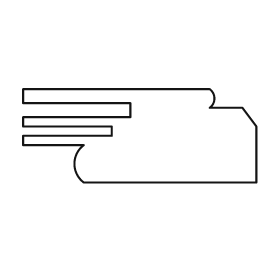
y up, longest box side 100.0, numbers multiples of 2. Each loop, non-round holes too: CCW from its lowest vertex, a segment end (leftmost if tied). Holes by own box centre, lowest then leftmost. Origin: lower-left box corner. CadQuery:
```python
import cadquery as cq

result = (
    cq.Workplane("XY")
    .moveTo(26.0, 0.0)
    .lineTo(100.0, 0.0)
    .lineTo(100.0, 24.0)
    .lineTo(94.0, 32.0)
    .lineTo(80.0, 32.0)
    .threePointArc((82.0, 36.0), (80.0, 40.0))
    .lineTo(0.0, 40.0)
    .lineTo(0.0, 34.0)
    .lineTo(46.0, 34.0)
    .lineTo(46.0, 28.0)
    .lineTo(0.0, 28.0)
    .lineTo(0.0, 24.0)
    .lineTo(38.0, 24.0)
    .lineTo(38.0, 20.0)
    .lineTo(0.0, 20.0)
    .lineTo(0.0, 16.0)
    .lineTo(26.0, 16.0)
    .threePointArc((22.0, 8.0), (26.0, 0.0))
    .close()
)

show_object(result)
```